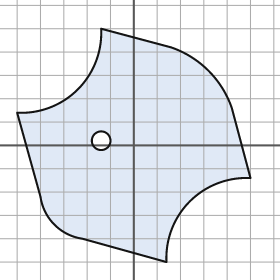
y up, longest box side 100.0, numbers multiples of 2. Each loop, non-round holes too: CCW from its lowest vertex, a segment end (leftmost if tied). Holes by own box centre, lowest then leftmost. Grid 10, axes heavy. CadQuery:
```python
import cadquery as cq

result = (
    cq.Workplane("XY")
    .moveTo(14.0, -50.0)
    .threePointArc((24.0, -24.0), (50.0, -14.0))
    .lineTo(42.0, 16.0)
    .threePointArc((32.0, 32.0), (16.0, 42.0))
    .lineTo(-14.0, 50.0)
    .threePointArc((-24.0, 24.0), (-50.0, 14.0))
    .lineTo(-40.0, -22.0)
    .threePointArc((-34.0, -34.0), (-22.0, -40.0))
    .close()
    .moveTo(-14.0, 2.0)
    .circle(4.0)
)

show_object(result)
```